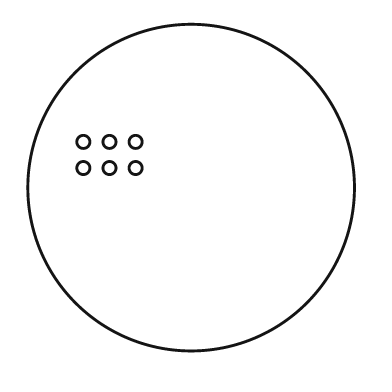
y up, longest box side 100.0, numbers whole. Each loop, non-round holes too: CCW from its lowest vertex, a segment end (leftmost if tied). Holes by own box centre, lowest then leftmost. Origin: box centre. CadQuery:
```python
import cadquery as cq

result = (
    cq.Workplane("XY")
    .moveTo(0.0, 0.0)
    .circle(50.0)
    .moveTo(-33.0, 6.0)
    .circle(2.0)
    .moveTo(-25.0, 6.0)
    .circle(2.0)
    .moveTo(-17.0, 6.0)
    .circle(2.0)
    .moveTo(-33.0, 14.0)
    .circle(2.0)
    .moveTo(-25.0, 14.0)
    .circle(2.0)
    .moveTo(-17.0, 14.0)
    .circle(2.0)
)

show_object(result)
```